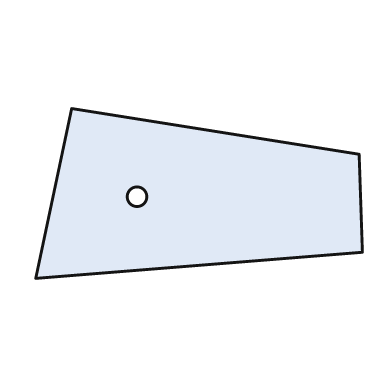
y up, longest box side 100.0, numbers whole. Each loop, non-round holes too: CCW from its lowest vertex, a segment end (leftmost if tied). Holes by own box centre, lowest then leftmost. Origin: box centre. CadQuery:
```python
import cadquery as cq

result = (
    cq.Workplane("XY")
    .moveTo(-50.0, -26.0)
    .lineTo(50.0, -18.0)
    .lineTo(49.0, 12.0)
    .lineTo(-39.0, 26.0)
    .close()
    .moveTo(-19.0, -1.0)
    .circle(3.0)
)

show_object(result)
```